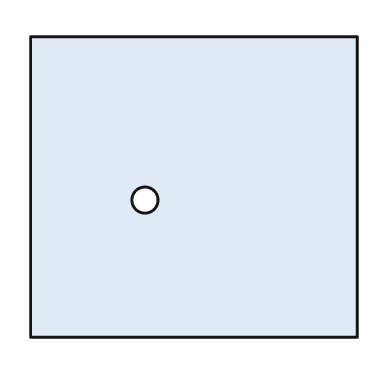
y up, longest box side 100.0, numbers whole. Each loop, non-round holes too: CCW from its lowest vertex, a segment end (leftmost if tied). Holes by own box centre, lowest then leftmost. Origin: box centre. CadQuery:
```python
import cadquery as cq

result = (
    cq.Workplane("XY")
    .moveTo(-50.0, -46.0)
    .lineTo(50.0, -46.0)
    .lineTo(50.0, 46.0)
    .lineTo(-50.0, 46.0)
    .close()
    .moveTo(-15.0, -4.0)
    .circle(4.0)
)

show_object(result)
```